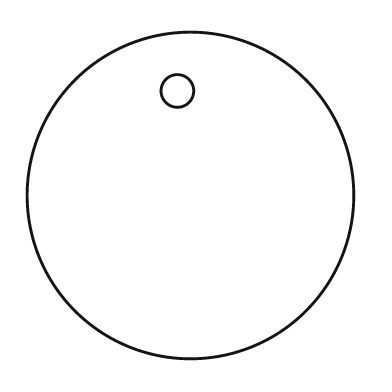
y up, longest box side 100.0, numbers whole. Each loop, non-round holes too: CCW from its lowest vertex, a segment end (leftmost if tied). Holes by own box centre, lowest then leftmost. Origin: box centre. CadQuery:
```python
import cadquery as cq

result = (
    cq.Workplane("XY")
    .moveTo(0.0, 0.0)
    .circle(50.0)
    .moveTo(-4.0, 32.0)
    .circle(5.0)
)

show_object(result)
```